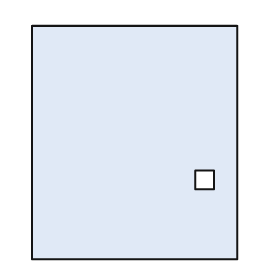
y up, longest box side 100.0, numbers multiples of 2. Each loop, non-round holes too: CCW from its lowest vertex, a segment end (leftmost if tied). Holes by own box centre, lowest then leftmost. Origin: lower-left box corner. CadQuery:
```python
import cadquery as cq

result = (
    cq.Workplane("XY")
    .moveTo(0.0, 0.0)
    .lineTo(88.0, 0.0)
    .lineTo(88.0, 100.0)
    .lineTo(0.0, 100.0)
    .close()
    .moveTo(70.0, 30.0)
    .lineTo(78.0, 30.0)
    .lineTo(78.0, 38.0)
    .lineTo(70.0, 38.0)
    .close()
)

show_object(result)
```